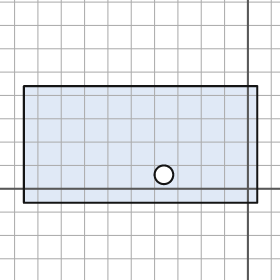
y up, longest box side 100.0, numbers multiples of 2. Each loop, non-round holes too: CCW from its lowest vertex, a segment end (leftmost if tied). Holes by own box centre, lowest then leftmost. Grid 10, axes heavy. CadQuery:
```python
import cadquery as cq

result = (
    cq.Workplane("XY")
    .moveTo(-96.0, -6.0)
    .lineTo(4.0, -6.0)
    .lineTo(4.0, 44.0)
    .lineTo(-96.0, 44.0)
    .close()
    .moveTo(-36.0, 6.0)
    .circle(4.0)
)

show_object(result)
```